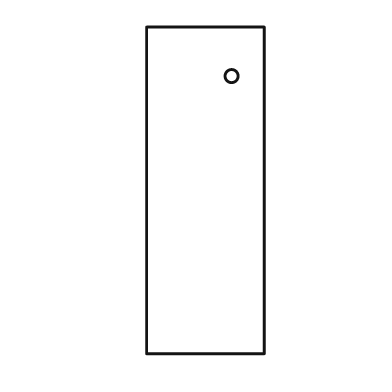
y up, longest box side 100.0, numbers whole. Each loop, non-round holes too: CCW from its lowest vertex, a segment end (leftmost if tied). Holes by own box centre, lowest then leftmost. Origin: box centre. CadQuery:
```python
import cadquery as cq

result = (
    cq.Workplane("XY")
    .moveTo(-18.0, -50.0)
    .lineTo(18.0, -50.0)
    .lineTo(18.0, 50.0)
    .lineTo(-18.0, 50.0)
    .close()
    .moveTo(8.0, 35.0)
    .circle(2.0)
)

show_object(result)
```